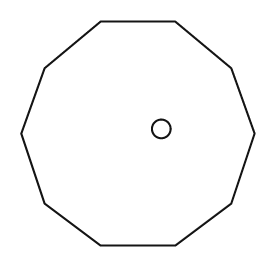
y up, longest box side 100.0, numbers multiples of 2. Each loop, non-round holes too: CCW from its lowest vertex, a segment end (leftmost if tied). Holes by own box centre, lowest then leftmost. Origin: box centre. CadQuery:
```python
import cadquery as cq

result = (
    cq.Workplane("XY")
    .moveTo(-16.0, -48.0)
    .lineTo(16.0, -48.0)
    .lineTo(40.0, -30.0)
    .lineTo(50.0, 0.0)
    .lineTo(40.0, 28.0)
    .lineTo(16.0, 48.0)
    .lineTo(-16.0, 48.0)
    .lineTo(-40.0, 28.0)
    .lineTo(-50.0, 0.0)
    .lineTo(-40.0, -30.0)
    .close()
    .moveTo(10.0, 2.0)
    .circle(4.0)
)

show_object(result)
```